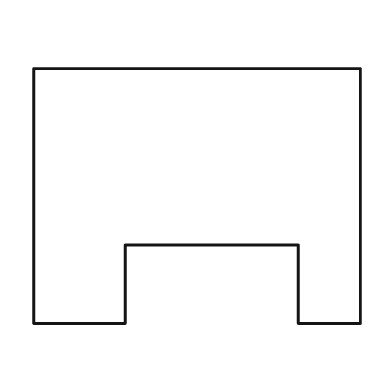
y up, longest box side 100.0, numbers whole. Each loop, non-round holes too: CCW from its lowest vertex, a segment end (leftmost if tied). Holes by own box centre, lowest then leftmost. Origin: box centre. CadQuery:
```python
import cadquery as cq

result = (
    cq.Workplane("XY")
    .moveTo(-50.0, -39.0)
    .lineTo(-22.0, -39.0)
    .lineTo(-22.0, -15.0)
    .lineTo(31.0, -15.0)
    .lineTo(31.0, -39.0)
    .lineTo(50.0, -39.0)
    .lineTo(50.0, 39.0)
    .lineTo(-50.0, 39.0)
    .close()
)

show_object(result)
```